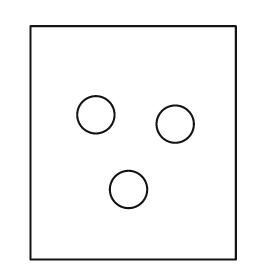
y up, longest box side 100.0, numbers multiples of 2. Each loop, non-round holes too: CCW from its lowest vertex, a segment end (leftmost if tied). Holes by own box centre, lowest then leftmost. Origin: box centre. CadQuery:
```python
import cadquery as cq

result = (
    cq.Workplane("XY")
    .moveTo(-44.0, -50.0)
    .lineTo(44.0, -50.0)
    .lineTo(44.0, 50.0)
    .lineTo(-44.0, 50.0)
    .close()
    .moveTo(-2.0, -20.0)
    .circle(8.0)
    .moveTo(18.0, 8.0)
    .circle(8.0)
    .moveTo(-16.0, 12.0)
    .circle(8.0)
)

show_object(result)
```